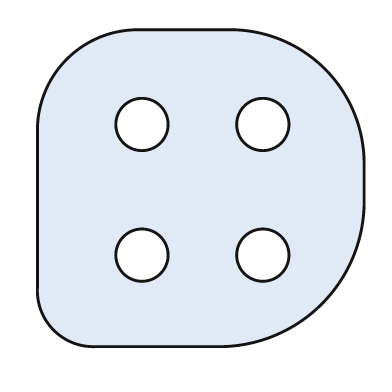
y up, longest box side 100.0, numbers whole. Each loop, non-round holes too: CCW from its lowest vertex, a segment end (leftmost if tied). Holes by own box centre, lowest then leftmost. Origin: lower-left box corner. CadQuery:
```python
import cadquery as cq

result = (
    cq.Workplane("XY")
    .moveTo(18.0, 0.0)
    .lineTo(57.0, 0.0)
    .threePointArc((87.0, 13.0), (100.0, 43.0))
    .lineTo(100.0, 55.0)
    .threePointArc((88.0, 85.0), (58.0, 97.0))
    .lineTo(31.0, 97.0)
    .threePointArc((9.0, 88.0), (0.0, 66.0))
    .lineTo(0.0, 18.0)
    .threePointArc((5.0, 5.0), (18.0, 0.0))
    .close()
    .moveTo(32.0, 28.0)
    .circle(8.0)
    .moveTo(69.0, 28.0)
    .circle(8.0)
    .moveTo(32.0, 68.0)
    .circle(8.0)
    .moveTo(69.0, 68.0)
    .circle(8.0)
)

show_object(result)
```